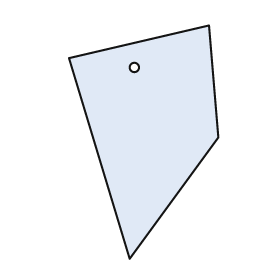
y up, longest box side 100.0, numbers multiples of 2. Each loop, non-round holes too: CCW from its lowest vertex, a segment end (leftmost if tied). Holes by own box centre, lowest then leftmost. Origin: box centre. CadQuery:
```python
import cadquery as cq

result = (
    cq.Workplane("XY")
    .moveTo(-6.0, -50.0)
    .lineTo(32.0, 2.0)
    .lineTo(28.0, 50.0)
    .lineTo(-32.0, 36.0)
    .close()
    .moveTo(-4.0, 32.0)
    .circle(2.0)
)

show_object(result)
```